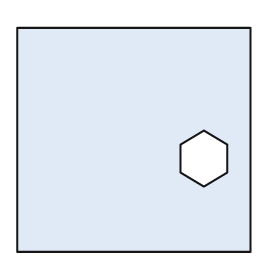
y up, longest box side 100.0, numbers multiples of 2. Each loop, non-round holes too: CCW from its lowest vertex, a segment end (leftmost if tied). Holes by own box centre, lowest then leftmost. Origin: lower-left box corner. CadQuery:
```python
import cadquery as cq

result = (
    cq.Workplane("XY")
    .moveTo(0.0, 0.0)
    .lineTo(100.0, 0.0)
    .lineTo(100.0, 96.0)
    .lineTo(0.0, 96.0)
    .close()
    .moveTo(80.0, 28.0)
    .lineTo(90.0, 34.0)
    .lineTo(90.0, 46.0)
    .lineTo(80.0, 52.0)
    .lineTo(70.0, 46.0)
    .lineTo(70.0, 34.0)
    .close()
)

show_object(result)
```